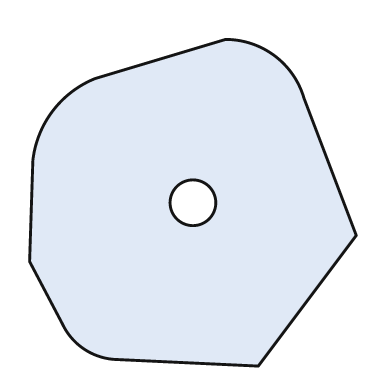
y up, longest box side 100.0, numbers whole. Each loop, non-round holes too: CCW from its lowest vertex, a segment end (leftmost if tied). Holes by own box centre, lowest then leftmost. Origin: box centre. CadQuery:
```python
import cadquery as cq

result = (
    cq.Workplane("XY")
    .moveTo(20.0, -50.0)
    .lineTo(50.0, -10.0)
    .lineTo(34.0, 32.0)
    .threePointArc((25.0, 45.0), (10.0, 50.0))
    .lineTo(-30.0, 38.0)
    .threePointArc((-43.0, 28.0), (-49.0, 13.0))
    .lineTo(-50.0, -18.0)
    .lineTo(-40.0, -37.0)
    .threePointArc((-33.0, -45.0), (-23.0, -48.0))
    .close()
    .moveTo(0.0, 0.0)
    .circle(7.0)
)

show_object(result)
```